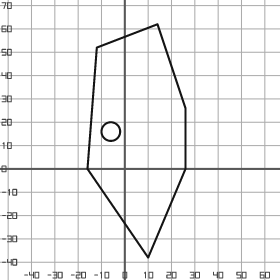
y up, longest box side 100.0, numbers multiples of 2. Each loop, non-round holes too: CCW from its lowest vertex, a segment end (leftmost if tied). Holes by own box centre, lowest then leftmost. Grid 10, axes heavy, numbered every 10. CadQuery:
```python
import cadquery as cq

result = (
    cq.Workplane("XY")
    .moveTo(10.0, -38.0)
    .lineTo(26.0, 0.0)
    .lineTo(26.0, 26.0)
    .lineTo(14.0, 62.0)
    .lineTo(-12.0, 52.0)
    .lineTo(-16.0, 0.0)
    .close()
    .moveTo(-6.0, 16.0)
    .circle(4.0)
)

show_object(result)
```